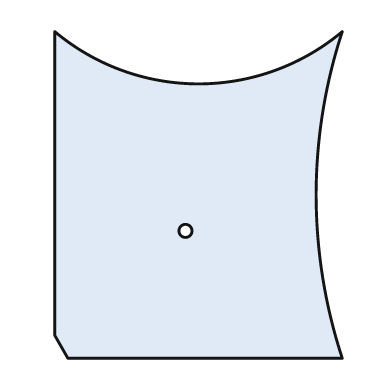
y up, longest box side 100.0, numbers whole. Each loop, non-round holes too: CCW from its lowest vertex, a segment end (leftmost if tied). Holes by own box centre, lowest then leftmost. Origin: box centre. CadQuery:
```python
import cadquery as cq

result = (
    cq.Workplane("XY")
    .moveTo(-40.0, -50.0)
    .lineTo(44.0, -50.0)
    .threePointArc((36.0, 0.0), (44.0, 50.0))
    .threePointArc((0.0, 34.0), (-44.0, 50.0))
    .lineTo(-44.0, -43.0)
    .close()
    .moveTo(-4.0, -11.0)
    .circle(2.0)
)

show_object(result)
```